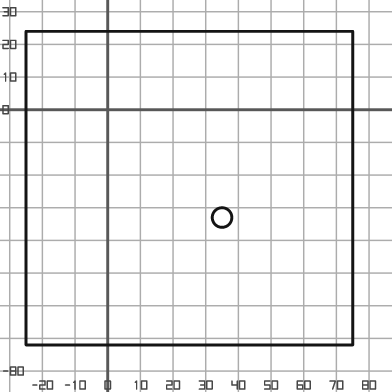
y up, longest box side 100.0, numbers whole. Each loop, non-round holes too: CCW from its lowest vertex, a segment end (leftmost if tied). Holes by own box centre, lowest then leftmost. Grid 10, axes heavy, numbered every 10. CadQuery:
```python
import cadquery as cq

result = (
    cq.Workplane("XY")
    .moveTo(-25.0, -72.0)
    .lineTo(75.0, -72.0)
    .lineTo(75.0, 24.0)
    .lineTo(-25.0, 24.0)
    .close()
    .moveTo(35.0, -33.0)
    .circle(3.0)
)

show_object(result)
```